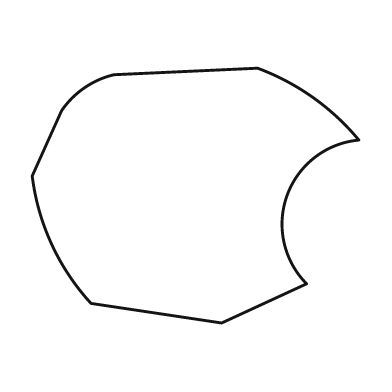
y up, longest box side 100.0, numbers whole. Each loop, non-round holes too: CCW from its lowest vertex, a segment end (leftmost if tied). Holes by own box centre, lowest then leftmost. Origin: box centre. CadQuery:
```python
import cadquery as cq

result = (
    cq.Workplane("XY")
    .moveTo(8.0, -39.0)
    .lineTo(34.0, -27.0)
    .threePointArc((28.0, 0.0), (50.0, 17.0))
    .threePointArc((36.0, 30.0), (19.0, 39.0))
    .lineTo(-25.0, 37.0)
    .threePointArc((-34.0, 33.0), (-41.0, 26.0))
    .lineTo(-50.0, 6.0)
    .threePointArc((-44.0, -15.0), (-32.0, -33.0))
    .close()
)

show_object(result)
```